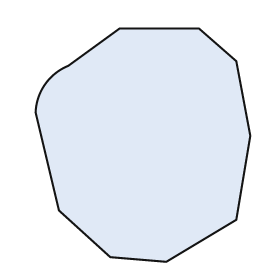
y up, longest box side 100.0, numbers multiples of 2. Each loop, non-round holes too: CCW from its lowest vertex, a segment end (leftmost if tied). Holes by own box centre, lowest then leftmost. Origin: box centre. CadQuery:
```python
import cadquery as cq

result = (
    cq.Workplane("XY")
    .moveTo(10.0, -50.0)
    .lineTo(40.0, -32.0)
    .lineTo(46.0, 4.0)
    .lineTo(40.0, 36.0)
    .lineTo(24.0, 50.0)
    .lineTo(-10.0, 50.0)
    .lineTo(-32.0, 34.0)
    .threePointArc((-42.0, 26.0), (-46.0, 14.0))
    .lineTo(-36.0, -28.0)
    .lineTo(-14.0, -48.0)
    .close()
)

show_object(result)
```